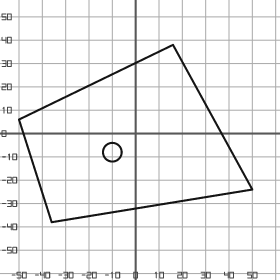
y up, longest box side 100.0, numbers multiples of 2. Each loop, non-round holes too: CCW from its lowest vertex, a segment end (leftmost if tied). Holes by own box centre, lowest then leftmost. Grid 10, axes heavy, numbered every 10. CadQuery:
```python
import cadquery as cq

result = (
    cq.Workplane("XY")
    .moveTo(-36.0, -38.0)
    .lineTo(50.0, -24.0)
    .lineTo(16.0, 38.0)
    .lineTo(-50.0, 6.0)
    .close()
    .moveTo(-10.0, -8.0)
    .circle(4.0)
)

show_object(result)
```